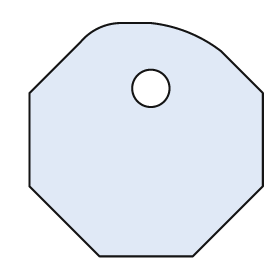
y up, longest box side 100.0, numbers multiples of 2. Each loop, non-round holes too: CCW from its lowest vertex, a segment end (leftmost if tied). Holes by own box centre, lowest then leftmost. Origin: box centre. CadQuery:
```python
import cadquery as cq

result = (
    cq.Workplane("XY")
    .moveTo(-20.0, -50.0)
    .lineTo(20.0, -50.0)
    .lineTo(50.0, -20.0)
    .lineTo(50.0, 20.0)
    .lineTo(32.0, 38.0)
    .threePointArc((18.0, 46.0), (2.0, 50.0))
    .lineTo(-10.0, 50.0)
    .threePointArc((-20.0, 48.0), (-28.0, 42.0))
    .lineTo(-50.0, 20.0)
    .lineTo(-50.0, -20.0)
    .close()
    .moveTo(2.0, 22.0)
    .circle(8.0)
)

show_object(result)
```